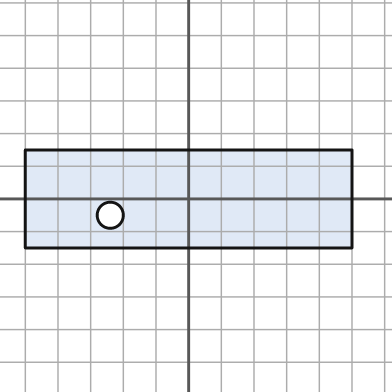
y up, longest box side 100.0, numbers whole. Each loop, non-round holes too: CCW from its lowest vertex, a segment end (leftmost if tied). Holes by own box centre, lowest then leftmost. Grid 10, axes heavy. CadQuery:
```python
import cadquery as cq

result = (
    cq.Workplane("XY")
    .moveTo(-50.0, -15.0)
    .lineTo(50.0, -15.0)
    .lineTo(50.0, 15.0)
    .lineTo(-50.0, 15.0)
    .close()
    .moveTo(-24.0, -5.0)
    .circle(4.0)
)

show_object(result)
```